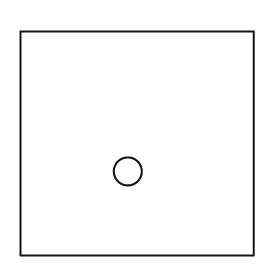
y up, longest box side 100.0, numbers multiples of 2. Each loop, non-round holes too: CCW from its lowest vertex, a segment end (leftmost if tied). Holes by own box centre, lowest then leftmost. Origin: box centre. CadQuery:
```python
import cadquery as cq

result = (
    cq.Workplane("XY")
    .moveTo(-50.0, -48.0)
    .lineTo(50.0, -48.0)
    .lineTo(50.0, 48.0)
    .lineTo(-50.0, 48.0)
    .close()
    .moveTo(-4.0, -12.0)
    .circle(6.0)
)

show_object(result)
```